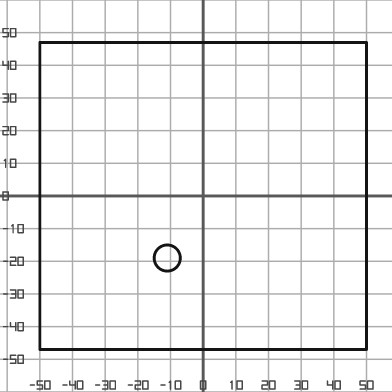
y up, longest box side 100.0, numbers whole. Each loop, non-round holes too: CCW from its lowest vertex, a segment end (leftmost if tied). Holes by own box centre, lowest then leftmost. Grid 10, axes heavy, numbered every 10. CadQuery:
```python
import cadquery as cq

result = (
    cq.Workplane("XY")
    .moveTo(-50.0, -47.0)
    .lineTo(50.0, -47.0)
    .lineTo(50.0, 47.0)
    .lineTo(-50.0, 47.0)
    .close()
    .moveTo(-11.0, -19.0)
    .circle(4.0)
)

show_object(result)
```